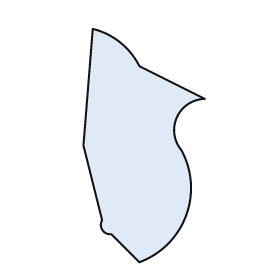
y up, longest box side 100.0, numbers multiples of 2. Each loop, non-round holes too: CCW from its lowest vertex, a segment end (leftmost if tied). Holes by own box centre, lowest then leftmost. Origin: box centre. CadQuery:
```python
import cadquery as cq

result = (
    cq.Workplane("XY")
    .moveTo(-2.0, -50.0)
    .threePointArc((18.0, -30.0), (16.0, -2.0))
    .threePointArc((14.0, 12.0), (26.0, 20.0))
    .lineTo(-2.0, 34.0)
    .threePointArc((-10.0, 44.0), (-22.0, 50.0))
    .lineTo(-26.0, 0.0)
    .lineTo(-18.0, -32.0)
    .threePointArc((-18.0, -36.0), (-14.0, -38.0))
    .close()
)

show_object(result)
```